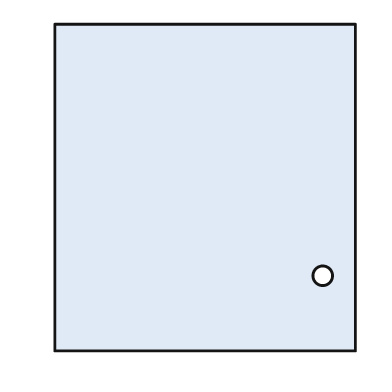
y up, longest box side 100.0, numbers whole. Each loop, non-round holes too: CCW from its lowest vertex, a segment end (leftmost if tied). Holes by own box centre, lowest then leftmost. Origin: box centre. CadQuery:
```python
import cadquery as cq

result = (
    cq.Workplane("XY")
    .moveTo(-46.0, -50.0)
    .lineTo(46.0, -50.0)
    .lineTo(46.0, 50.0)
    .lineTo(-46.0, 50.0)
    .close()
    .moveTo(36.0, -27.0)
    .circle(3.0)
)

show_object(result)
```